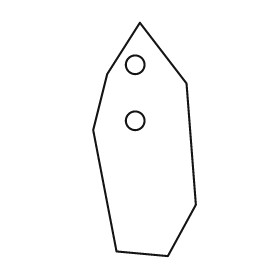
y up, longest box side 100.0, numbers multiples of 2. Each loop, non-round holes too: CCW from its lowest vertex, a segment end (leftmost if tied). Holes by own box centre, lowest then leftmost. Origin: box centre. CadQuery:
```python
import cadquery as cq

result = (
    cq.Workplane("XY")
    .moveTo(10.0, -50.0)
    .lineTo(22.0, -28.0)
    .lineTo(18.0, 24.0)
    .lineTo(-2.0, 50.0)
    .lineTo(-16.0, 28.0)
    .lineTo(-22.0, 4.0)
    .lineTo(-12.0, -48.0)
    .close()
    .moveTo(-4.0, 8.0)
    .circle(4.0)
    .moveTo(-4.0, 32.0)
    .circle(4.0)
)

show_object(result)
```